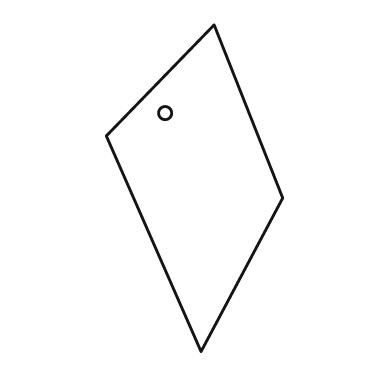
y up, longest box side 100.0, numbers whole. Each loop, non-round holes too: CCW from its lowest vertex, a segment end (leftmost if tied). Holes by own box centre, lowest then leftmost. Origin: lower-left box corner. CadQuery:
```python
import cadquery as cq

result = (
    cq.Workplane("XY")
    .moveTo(29.0, 0.0)
    .lineTo(54.0, 47.0)
    .lineTo(33.0, 100.0)
    .lineTo(0.0, 66.0)
    .close()
    .moveTo(18.0, 73.0)
    .circle(2.0)
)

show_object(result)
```